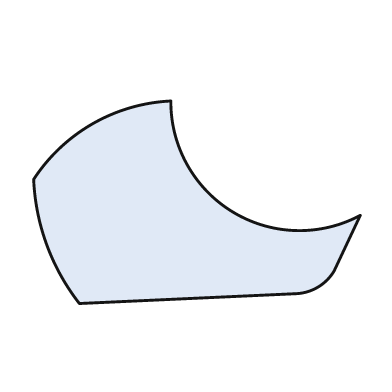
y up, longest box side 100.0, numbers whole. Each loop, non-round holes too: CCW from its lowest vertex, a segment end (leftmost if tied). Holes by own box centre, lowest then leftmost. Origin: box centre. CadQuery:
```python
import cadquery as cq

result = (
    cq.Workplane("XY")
    .moveTo(-36.0, -31.0)
    .lineTo(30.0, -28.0)
    .threePointArc((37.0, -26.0), (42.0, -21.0))
    .lineTo(50.0, -4.0)
    .threePointArc((11.0, -3.0), (-8.0, 31.0))
    .threePointArc((-32.0, 24.0), (-50.0, 7.0))
    .threePointArc((-46.0, -13.0), (-36.0, -31.0))
    .close()
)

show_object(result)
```